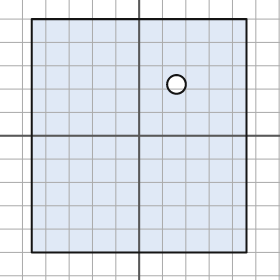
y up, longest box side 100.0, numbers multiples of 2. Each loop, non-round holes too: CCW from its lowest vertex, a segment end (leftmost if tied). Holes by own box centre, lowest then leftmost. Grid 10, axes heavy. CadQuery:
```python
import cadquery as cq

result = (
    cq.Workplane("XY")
    .moveTo(-46.0, -50.0)
    .lineTo(46.0, -50.0)
    .lineTo(46.0, 50.0)
    .lineTo(-46.0, 50.0)
    .close()
    .moveTo(16.0, 22.0)
    .circle(4.0)
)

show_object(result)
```